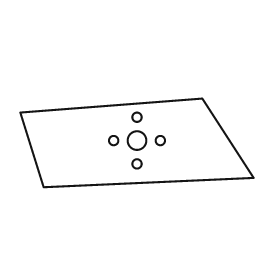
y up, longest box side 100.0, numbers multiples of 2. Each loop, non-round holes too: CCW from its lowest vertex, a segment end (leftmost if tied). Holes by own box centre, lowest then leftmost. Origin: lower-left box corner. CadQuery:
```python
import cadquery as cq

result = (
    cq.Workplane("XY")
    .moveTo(10.0, 0.0)
    .lineTo(100.0, 4.0)
    .lineTo(78.0, 38.0)
    .lineTo(0.0, 32.0)
    .close()
    .moveTo(50.0, 10.0)
    .circle(2.0)
    .moveTo(40.0, 20.0)
    .circle(2.0)
    .moveTo(50.0, 20.0)
    .circle(4.0)
    .moveTo(60.0, 20.0)
    .circle(2.0)
    .moveTo(50.0, 30.0)
    .circle(2.0)
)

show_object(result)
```